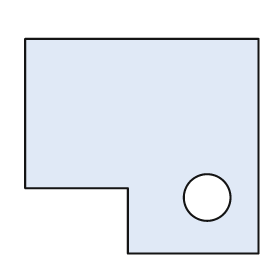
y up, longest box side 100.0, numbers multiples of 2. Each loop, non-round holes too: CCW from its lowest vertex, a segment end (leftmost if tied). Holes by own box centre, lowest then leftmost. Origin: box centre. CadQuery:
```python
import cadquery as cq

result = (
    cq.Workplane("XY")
    .moveTo(-6.0, -46.0)
    .lineTo(50.0, -46.0)
    .lineTo(50.0, 46.0)
    .lineTo(-50.0, 46.0)
    .lineTo(-50.0, -18.0)
    .lineTo(-6.0, -18.0)
    .close()
    .moveTo(28.0, -22.0)
    .circle(10.0)
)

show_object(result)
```